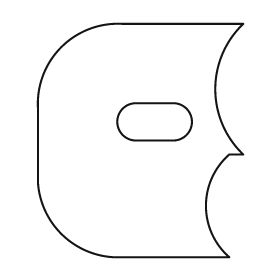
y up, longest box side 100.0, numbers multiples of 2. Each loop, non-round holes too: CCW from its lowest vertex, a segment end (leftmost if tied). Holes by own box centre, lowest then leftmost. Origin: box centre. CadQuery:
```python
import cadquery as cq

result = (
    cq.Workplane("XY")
    .moveTo(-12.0, -50.0)
    .lineTo(38.0, -50.0)
    .threePointArc((28.0, -28.0), (38.0, -6.0))
    .lineTo(44.0, -6.0)
    .threePointArc((32.0, 22.0), (44.0, 50.0))
    .lineTo(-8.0, 50.0)
    .threePointArc((-34.0, 40.0), (-44.0, 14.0))
    .lineTo(-44.0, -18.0)
    .threePointArc((-34.0, -40.0), (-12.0, -50.0))
    .close()
    .moveTo(-2.0, 0.0)
    .lineTo(14.0, 0.0)
    .threePointArc((22.0, 8.0), (14.0, 16.0))
    .lineTo(-2.0, 16.0)
    .threePointArc((-10.0, 8.0), (-2.0, 0.0))
    .close()
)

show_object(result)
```